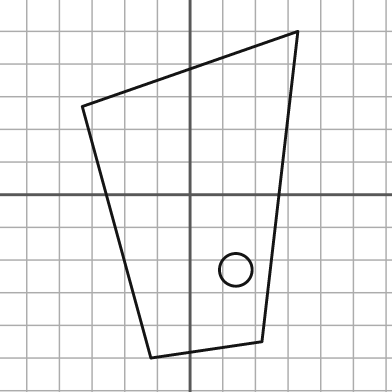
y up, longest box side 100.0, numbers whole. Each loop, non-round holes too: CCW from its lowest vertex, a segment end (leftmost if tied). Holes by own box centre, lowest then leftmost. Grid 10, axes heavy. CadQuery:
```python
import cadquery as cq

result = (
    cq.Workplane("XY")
    .moveTo(-12.0, -50.0)
    .lineTo(22.0, -45.0)
    .lineTo(33.0, 50.0)
    .lineTo(-33.0, 27.0)
    .close()
    .moveTo(14.0, -23.0)
    .circle(5.0)
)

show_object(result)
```